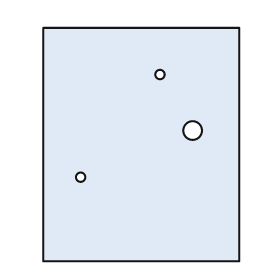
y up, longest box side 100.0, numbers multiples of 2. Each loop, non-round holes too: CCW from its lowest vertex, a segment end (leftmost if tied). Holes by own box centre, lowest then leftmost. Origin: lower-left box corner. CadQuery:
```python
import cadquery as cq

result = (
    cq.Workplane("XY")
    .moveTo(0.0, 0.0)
    .lineTo(84.0, 0.0)
    .lineTo(84.0, 100.0)
    .lineTo(0.0, 100.0)
    .close()
    .moveTo(16.0, 36.0)
    .circle(2.0)
    .moveTo(64.0, 56.0)
    .circle(4.0)
    .moveTo(50.0, 80.0)
    .circle(2.0)
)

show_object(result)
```